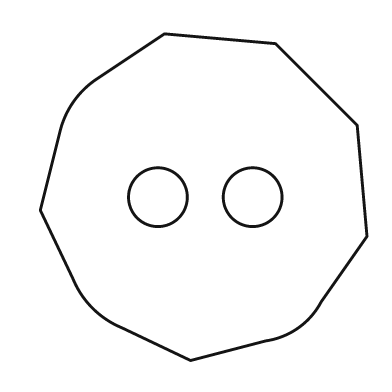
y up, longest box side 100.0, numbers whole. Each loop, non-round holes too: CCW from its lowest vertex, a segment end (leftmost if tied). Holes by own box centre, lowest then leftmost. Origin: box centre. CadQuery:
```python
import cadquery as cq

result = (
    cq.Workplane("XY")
    .moveTo(-4.0, -50.0)
    .lineTo(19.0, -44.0)
    .threePointArc((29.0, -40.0), (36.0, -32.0))
    .lineTo(50.0, -12.0)
    .lineTo(47.0, 22.0)
    .lineTo(22.0, 47.0)
    .lineTo(-12.0, 50.0)
    .lineTo(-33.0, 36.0)
    .threePointArc((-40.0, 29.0), (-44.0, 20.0))
    .lineTo(-50.0, -4.0)
    .lineTo(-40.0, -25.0)
    .threePointArc((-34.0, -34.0), (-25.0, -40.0))
    .close()
    .moveTo(-14.0, 0.0)
    .circle(9.0)
    .moveTo(15.0, 0.0)
    .circle(9.0)
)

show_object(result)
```